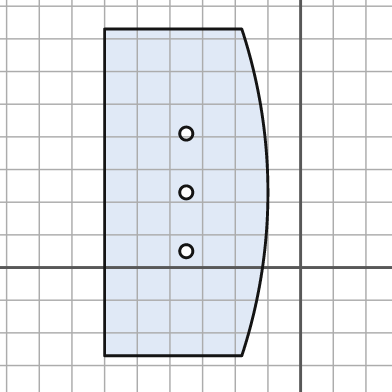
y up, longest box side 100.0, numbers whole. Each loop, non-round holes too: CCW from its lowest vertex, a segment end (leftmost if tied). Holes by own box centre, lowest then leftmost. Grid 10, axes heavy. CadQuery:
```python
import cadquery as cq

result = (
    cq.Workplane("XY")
    .moveTo(-60.0, -27.0)
    .lineTo(-18.0, -27.0)
    .threePointArc((-10.0, 23.0), (-18.0, 73.0))
    .lineTo(-60.0, 73.0)
    .close()
    .moveTo(-35.0, 5.0)
    .circle(2.0)
    .moveTo(-35.0, 23.0)
    .circle(2.0)
    .moveTo(-35.0, 41.0)
    .circle(2.0)
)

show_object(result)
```